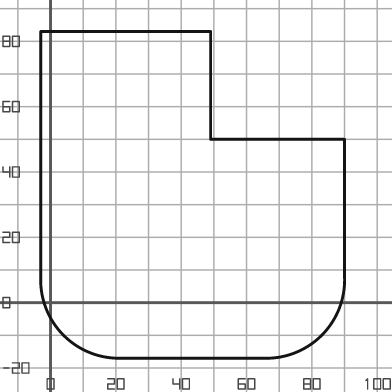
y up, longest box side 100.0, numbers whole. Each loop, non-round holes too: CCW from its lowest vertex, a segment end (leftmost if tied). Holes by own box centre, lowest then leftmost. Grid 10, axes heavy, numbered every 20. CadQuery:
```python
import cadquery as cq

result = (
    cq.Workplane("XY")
    .moveTo(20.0, -17.0)
    .lineTo(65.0, -17.0)
    .threePointArc((83.0, -10.0), (90.0, 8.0))
    .lineTo(90.0, 50.0)
    .lineTo(49.0, 50.0)
    .lineTo(49.0, 83.0)
    .lineTo(-3.0, 83.0)
    .lineTo(-3.0, 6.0)
    .threePointArc((4.0, -10.0), (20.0, -17.0))
    .close()
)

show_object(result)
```